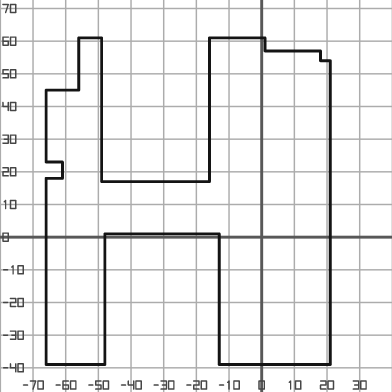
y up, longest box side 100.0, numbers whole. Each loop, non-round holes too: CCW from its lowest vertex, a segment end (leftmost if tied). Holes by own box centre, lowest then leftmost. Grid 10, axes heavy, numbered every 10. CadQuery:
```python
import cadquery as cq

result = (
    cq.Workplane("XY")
    .moveTo(-66.0, -39.0)
    .lineTo(-48.0, -39.0)
    .lineTo(-48.0, 1.0)
    .lineTo(-13.0, 1.0)
    .lineTo(-13.0, -39.0)
    .lineTo(21.0, -39.0)
    .lineTo(21.0, 54.0)
    .lineTo(18.0, 54.0)
    .lineTo(18.0, 57.0)
    .lineTo(1.0, 57.0)
    .lineTo(1.0, 61.0)
    .lineTo(-16.0, 61.0)
    .lineTo(-16.0, 17.0)
    .lineTo(-49.0, 17.0)
    .lineTo(-49.0, 61.0)
    .lineTo(-56.0, 61.0)
    .lineTo(-56.0, 45.0)
    .lineTo(-66.0, 45.0)
    .lineTo(-66.0, 23.0)
    .lineTo(-61.0, 23.0)
    .lineTo(-61.0, 18.0)
    .lineTo(-66.0, 18.0)
    .close()
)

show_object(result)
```